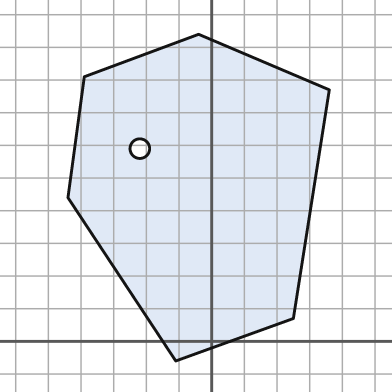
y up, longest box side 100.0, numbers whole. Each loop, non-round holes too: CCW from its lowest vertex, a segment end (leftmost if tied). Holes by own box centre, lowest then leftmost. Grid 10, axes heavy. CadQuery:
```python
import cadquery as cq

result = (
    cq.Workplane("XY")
    .moveTo(-11.0, -6.0)
    .lineTo(25.0, 7.0)
    .lineTo(36.0, 77.0)
    .lineTo(-4.0, 94.0)
    .lineTo(-39.0, 81.0)
    .lineTo(-44.0, 44.0)
    .close()
    .moveTo(-22.0, 59.0)
    .circle(3.0)
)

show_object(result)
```